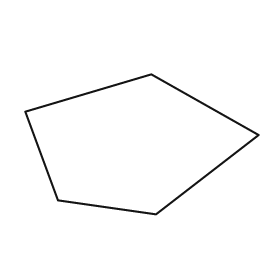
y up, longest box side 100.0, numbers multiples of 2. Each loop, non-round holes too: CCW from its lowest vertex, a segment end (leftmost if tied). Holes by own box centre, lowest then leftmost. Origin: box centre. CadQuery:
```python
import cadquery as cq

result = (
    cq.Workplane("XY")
    .moveTo(6.0, -30.0)
    .lineTo(50.0, 4.0)
    .lineTo(4.0, 30.0)
    .lineTo(-50.0, 14.0)
    .lineTo(-36.0, -24.0)
    .close()
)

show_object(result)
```